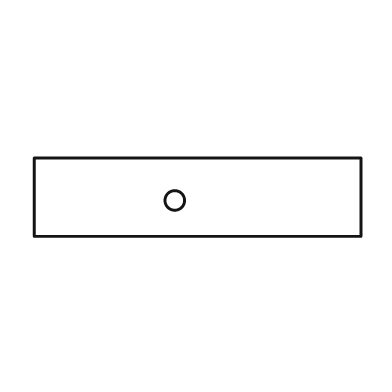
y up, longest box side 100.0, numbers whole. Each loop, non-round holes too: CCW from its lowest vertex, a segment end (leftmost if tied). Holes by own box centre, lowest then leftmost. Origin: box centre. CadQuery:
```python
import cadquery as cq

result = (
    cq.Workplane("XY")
    .moveTo(-50.0, -12.0)
    .lineTo(50.0, -12.0)
    .lineTo(50.0, 12.0)
    .lineTo(-50.0, 12.0)
    .close()
    .moveTo(-7.0, -1.0)
    .circle(3.0)
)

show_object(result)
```